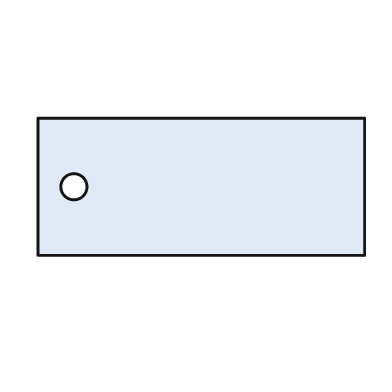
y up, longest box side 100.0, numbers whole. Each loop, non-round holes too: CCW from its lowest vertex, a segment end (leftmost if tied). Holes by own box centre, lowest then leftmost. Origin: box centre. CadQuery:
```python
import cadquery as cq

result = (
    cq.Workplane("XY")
    .moveTo(-50.0, -21.0)
    .lineTo(50.0, -21.0)
    .lineTo(50.0, 21.0)
    .lineTo(-50.0, 21.0)
    .close()
    .moveTo(-39.0, 0.0)
    .circle(4.0)
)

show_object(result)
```